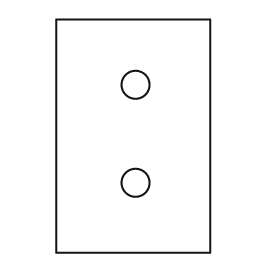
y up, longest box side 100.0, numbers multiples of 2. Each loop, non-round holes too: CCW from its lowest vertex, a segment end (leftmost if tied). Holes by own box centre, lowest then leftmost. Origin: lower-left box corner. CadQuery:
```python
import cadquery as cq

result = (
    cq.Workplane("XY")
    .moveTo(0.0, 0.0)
    .lineTo(66.0, 0.0)
    .lineTo(66.0, 100.0)
    .lineTo(0.0, 100.0)
    .close()
    .moveTo(34.0, 30.0)
    .circle(6.0)
    .moveTo(34.0, 72.0)
    .circle(6.0)
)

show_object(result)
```